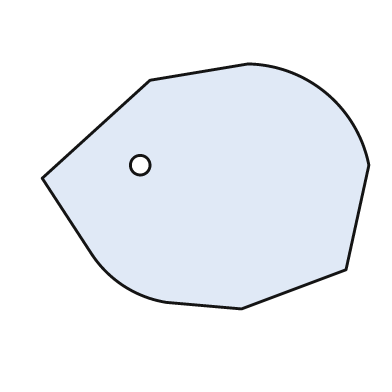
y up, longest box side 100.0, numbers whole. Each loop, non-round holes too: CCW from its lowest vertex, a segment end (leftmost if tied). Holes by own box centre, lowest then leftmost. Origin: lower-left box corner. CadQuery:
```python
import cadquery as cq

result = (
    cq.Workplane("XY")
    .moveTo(61.0, 0.0)
    .lineTo(93.0, 12.0)
    .lineTo(100.0, 44.0)
    .threePointArc((87.0, 66.0), (63.0, 75.0))
    .lineTo(33.0, 70.0)
    .lineTo(0.0, 40.0)
    .lineTo(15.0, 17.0)
    .threePointArc((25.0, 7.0), (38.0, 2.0))
    .close()
    .moveTo(30.0, 44.0)
    .circle(3.0)
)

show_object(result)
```